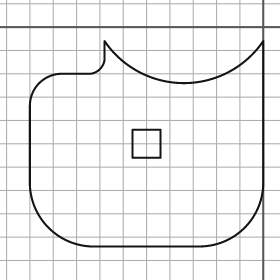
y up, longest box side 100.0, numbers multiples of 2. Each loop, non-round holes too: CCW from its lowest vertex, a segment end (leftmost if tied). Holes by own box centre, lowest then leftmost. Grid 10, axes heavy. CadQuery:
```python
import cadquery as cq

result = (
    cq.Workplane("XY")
    .moveTo(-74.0, -94.0)
    .lineTo(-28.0, -94.0)
    .threePointArc((-8.0, -86.0), (0.0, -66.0))
    .lineTo(0.0, -6.0)
    .threePointArc((-34.0, -24.0), (-68.0, -6.0))
    .lineTo(-68.0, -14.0)
    .threePointArc((-70.0, -18.0), (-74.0, -20.0))
    .lineTo(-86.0, -20.0)
    .threePointArc((-96.0, -24.0), (-100.0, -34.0))
    .lineTo(-100.0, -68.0)
    .threePointArc((-92.0, -86.0), (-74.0, -94.0))
    .close()
    .moveTo(-56.0, -56.0)
    .lineTo(-44.0, -56.0)
    .lineTo(-44.0, -44.0)
    .lineTo(-56.0, -44.0)
    .close()
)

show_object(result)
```